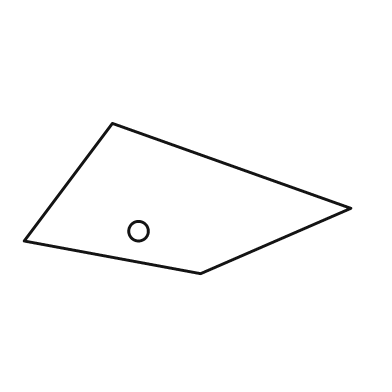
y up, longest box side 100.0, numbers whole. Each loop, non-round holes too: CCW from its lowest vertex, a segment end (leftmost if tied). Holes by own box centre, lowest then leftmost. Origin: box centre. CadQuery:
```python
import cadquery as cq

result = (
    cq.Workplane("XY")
    .moveTo(4.0, -23.0)
    .lineTo(50.0, -3.0)
    .lineTo(-23.0, 23.0)
    .lineTo(-50.0, -13.0)
    .close()
    .moveTo(-15.0, -10.0)
    .circle(3.0)
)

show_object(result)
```